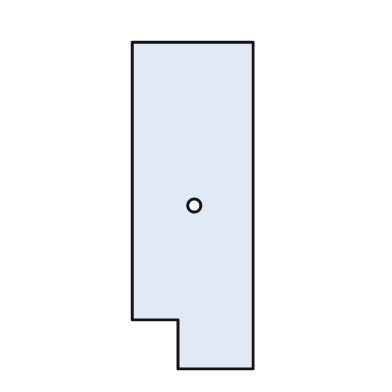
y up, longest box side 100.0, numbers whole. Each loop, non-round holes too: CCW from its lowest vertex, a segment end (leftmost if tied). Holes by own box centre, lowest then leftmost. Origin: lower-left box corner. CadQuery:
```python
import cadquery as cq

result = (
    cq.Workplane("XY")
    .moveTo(14.0, 0.0)
    .lineTo(37.0, 0.0)
    .lineTo(37.0, 100.0)
    .lineTo(0.0, 100.0)
    .lineTo(0.0, 15.0)
    .lineTo(14.0, 15.0)
    .close()
    .moveTo(19.0, 50.0)
    .circle(2.0)
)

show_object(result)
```